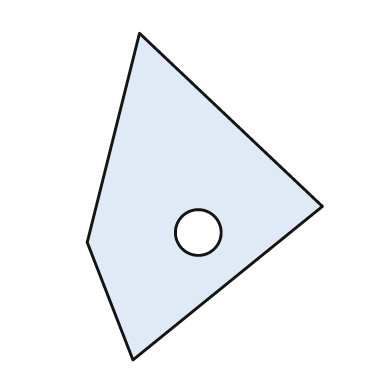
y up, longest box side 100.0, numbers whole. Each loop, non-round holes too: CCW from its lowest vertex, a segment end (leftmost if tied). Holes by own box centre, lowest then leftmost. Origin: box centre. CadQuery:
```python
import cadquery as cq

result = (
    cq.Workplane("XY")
    .moveTo(-22.0, -50.0)
    .lineTo(36.0, -3.0)
    .lineTo(-20.0, 50.0)
    .lineTo(-36.0, -14.0)
    .close()
    .moveTo(-2.0, -11.0)
    .circle(7.0)
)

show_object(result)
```